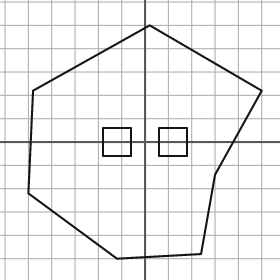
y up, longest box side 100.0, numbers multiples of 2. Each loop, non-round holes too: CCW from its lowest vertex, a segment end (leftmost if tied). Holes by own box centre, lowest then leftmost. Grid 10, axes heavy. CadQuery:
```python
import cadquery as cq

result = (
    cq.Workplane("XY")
    .moveTo(-12.0, -50.0)
    .lineTo(24.0, -48.0)
    .lineTo(30.0, -14.0)
    .lineTo(50.0, 22.0)
    .lineTo(2.0, 50.0)
    .lineTo(-48.0, 22.0)
    .lineTo(-50.0, -22.0)
    .close()
    .moveTo(-18.0, -6.0)
    .lineTo(-6.0, -6.0)
    .lineTo(-6.0, 6.0)
    .lineTo(-18.0, 6.0)
    .close()
    .moveTo(6.0, -6.0)
    .lineTo(18.0, -6.0)
    .lineTo(18.0, 6.0)
    .lineTo(6.0, 6.0)
    .close()
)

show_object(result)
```